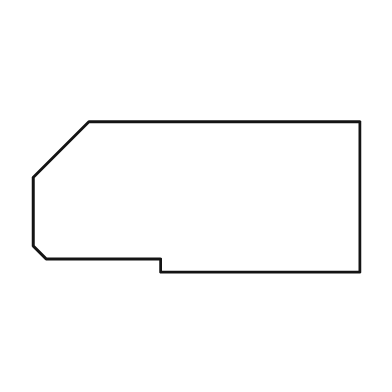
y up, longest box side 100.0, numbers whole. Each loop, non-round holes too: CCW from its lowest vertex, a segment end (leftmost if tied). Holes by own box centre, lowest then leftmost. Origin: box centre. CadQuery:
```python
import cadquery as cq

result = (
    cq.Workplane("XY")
    .moveTo(-11.0, -23.0)
    .lineTo(50.0, -23.0)
    .lineTo(50.0, 23.0)
    .lineTo(-33.0, 23.0)
    .lineTo(-50.0, 6.0)
    .lineTo(-50.0, -15.0)
    .lineTo(-46.0, -19.0)
    .lineTo(-11.0, -19.0)
    .close()
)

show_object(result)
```